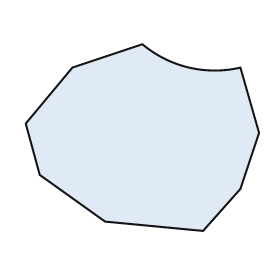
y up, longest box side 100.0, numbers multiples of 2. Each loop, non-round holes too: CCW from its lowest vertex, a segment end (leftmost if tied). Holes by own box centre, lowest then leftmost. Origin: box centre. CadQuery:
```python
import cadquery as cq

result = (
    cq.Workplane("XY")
    .moveTo(26.0, -40.0)
    .lineTo(42.0, -22.0)
    .lineTo(50.0, 2.0)
    .lineTo(42.0, 30.0)
    .threePointArc((20.0, 30.0), (0.0, 40.0))
    .lineTo(-30.0, 30.0)
    .lineTo(-50.0, 6.0)
    .lineTo(-44.0, -16.0)
    .lineTo(-16.0, -36.0)
    .close()
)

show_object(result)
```